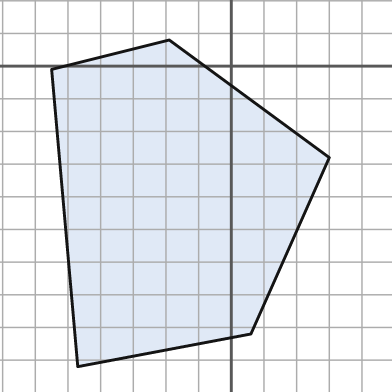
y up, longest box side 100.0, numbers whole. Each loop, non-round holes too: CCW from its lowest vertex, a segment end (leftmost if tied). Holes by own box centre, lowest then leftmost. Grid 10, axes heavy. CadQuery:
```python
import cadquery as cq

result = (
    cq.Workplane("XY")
    .moveTo(-47.0, -92.0)
    .lineTo(6.0, -82.0)
    .lineTo(30.0, -28.0)
    .lineTo(-19.0, 8.0)
    .lineTo(-55.0, -1.0)
    .close()
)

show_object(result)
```